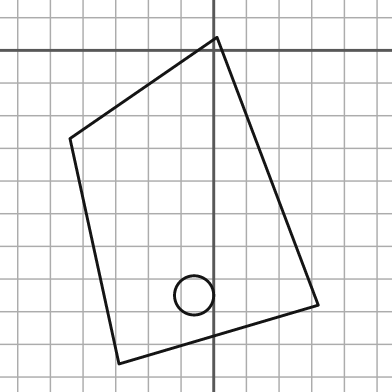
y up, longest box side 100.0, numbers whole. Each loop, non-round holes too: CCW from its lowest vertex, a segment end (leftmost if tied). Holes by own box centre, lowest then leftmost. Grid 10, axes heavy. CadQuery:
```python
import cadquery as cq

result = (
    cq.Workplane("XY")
    .moveTo(-29.0, -96.0)
    .lineTo(32.0, -78.0)
    .lineTo(1.0, 4.0)
    .lineTo(-44.0, -27.0)
    .close()
    .moveTo(-6.0, -75.0)
    .circle(6.0)
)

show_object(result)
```